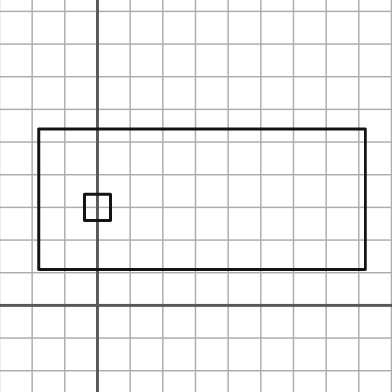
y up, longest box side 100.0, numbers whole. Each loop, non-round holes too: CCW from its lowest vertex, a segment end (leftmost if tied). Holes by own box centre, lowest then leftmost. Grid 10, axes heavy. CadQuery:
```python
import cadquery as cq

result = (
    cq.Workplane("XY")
    .moveTo(-18.0, 11.0)
    .lineTo(82.0, 11.0)
    .lineTo(82.0, 54.0)
    .lineTo(-18.0, 54.0)
    .close()
    .moveTo(-4.0, 26.0)
    .lineTo(4.0, 26.0)
    .lineTo(4.0, 34.0)
    .lineTo(-4.0, 34.0)
    .close()
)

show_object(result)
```